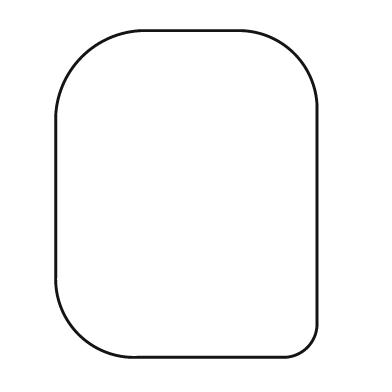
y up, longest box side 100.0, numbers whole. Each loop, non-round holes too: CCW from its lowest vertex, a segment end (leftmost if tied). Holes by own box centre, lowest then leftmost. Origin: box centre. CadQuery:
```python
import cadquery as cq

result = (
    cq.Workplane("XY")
    .moveTo(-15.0, -50.0)
    .lineTo(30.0, -50.0)
    .threePointArc((37.0, -47.0), (40.0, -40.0))
    .lineTo(40.0, 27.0)
    .threePointArc((33.0, 43.0), (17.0, 50.0))
    .lineTo(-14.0, 50.0)
    .threePointArc((-32.0, 42.0), (-40.0, 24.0))
    .lineTo(-40.0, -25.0)
    .threePointArc((-33.0, -43.0), (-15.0, -50.0))
    .close()
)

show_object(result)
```